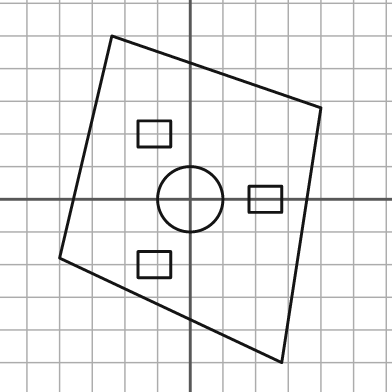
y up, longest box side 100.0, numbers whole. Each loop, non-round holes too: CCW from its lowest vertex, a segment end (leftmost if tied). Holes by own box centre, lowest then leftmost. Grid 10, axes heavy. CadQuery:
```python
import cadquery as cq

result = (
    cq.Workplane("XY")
    .moveTo(28.0, -50.0)
    .lineTo(40.0, 28.0)
    .lineTo(-24.0, 50.0)
    .lineTo(-40.0, -18.0)
    .close()
    .moveTo(-16.0, -24.0)
    .lineTo(-6.0, -24.0)
    .lineTo(-6.0, -16.0)
    .lineTo(-16.0, -16.0)
    .close()
    .moveTo(0.0, 0.0)
    .circle(10.0)
    .moveTo(18.0, -4.0)
    .lineTo(28.0, -4.0)
    .lineTo(28.0, 4.0)
    .lineTo(18.0, 4.0)
    .close()
    .moveTo(-16.0, 16.0)
    .lineTo(-6.0, 16.0)
    .lineTo(-6.0, 24.0)
    .lineTo(-16.0, 24.0)
    .close()
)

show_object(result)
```